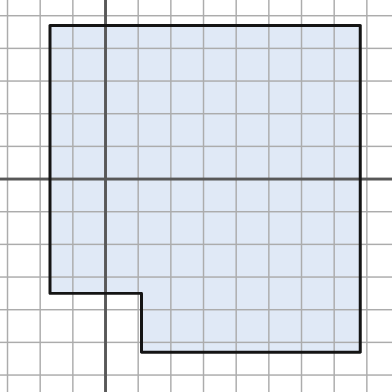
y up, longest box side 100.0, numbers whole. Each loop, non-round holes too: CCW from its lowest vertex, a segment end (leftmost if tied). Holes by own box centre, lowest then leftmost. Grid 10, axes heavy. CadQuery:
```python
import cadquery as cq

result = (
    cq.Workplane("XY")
    .moveTo(11.0, -53.0)
    .lineTo(78.0, -53.0)
    .lineTo(78.0, 47.0)
    .lineTo(-17.0, 47.0)
    .lineTo(-17.0, -35.0)
    .lineTo(11.0, -35.0)
    .close()
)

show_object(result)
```